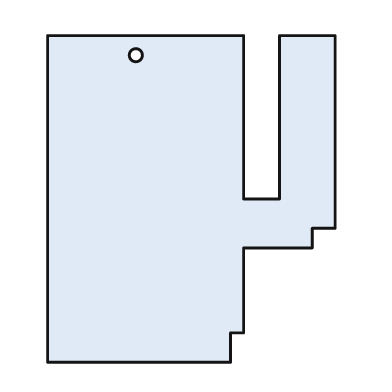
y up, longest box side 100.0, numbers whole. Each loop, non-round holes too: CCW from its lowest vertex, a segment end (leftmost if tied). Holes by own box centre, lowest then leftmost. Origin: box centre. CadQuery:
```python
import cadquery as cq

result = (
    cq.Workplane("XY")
    .moveTo(-44.0, -50.0)
    .lineTo(12.0, -50.0)
    .lineTo(12.0, -41.0)
    .lineTo(16.0, -41.0)
    .lineTo(16.0, -15.0)
    .lineTo(37.0, -15.0)
    .lineTo(37.0, -9.0)
    .lineTo(44.0, -9.0)
    .lineTo(44.0, 50.0)
    .lineTo(27.0, 50.0)
    .lineTo(27.0, 0.0)
    .lineTo(16.0, 0.0)
    .lineTo(16.0, 50.0)
    .lineTo(-44.0, 50.0)
    .close()
    .moveTo(-17.0, 44.0)
    .circle(2.0)
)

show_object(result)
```